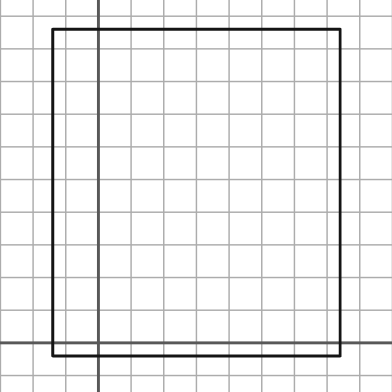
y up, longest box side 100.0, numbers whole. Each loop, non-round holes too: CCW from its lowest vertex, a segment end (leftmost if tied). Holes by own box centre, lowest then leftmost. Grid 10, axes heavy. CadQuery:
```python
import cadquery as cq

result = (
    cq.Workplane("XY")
    .moveTo(-14.0, -4.0)
    .lineTo(74.0, -4.0)
    .lineTo(74.0, 96.0)
    .lineTo(-14.0, 96.0)
    .close()
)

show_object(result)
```